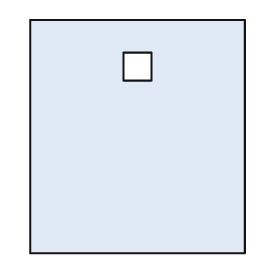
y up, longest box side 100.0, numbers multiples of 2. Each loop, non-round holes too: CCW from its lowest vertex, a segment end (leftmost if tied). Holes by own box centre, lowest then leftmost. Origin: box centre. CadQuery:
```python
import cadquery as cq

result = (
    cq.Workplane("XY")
    .moveTo(-46.0, -50.0)
    .lineTo(46.0, -50.0)
    .lineTo(46.0, 50.0)
    .lineTo(-46.0, 50.0)
    .close()
    .moveTo(-6.0, 24.0)
    .lineTo(6.0, 24.0)
    .lineTo(6.0, 36.0)
    .lineTo(-6.0, 36.0)
    .close()
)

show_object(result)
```